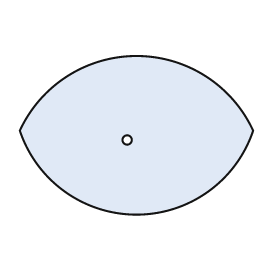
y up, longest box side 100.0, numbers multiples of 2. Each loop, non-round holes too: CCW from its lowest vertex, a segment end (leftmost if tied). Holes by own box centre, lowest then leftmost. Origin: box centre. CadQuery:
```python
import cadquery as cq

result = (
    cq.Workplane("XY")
    .moveTo(-50.0, 2.0)
    .threePointArc((0.0, -34.0), (50.0, 2.0))
    .threePointArc((0.0, 34.0), (-50.0, 2.0))
    .close()
    .moveTo(-4.0, -2.0)
    .circle(2.0)
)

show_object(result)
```